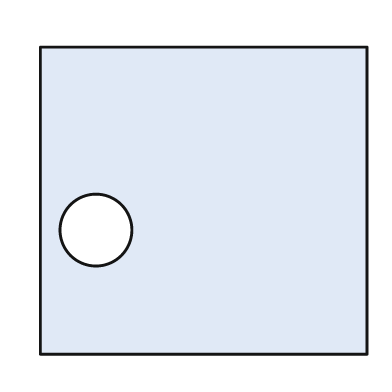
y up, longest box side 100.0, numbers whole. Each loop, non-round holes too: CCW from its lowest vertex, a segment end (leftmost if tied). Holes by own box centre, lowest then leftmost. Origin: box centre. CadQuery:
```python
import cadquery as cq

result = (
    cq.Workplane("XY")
    .moveTo(-50.0, -47.0)
    .lineTo(50.0, -47.0)
    .lineTo(50.0, 47.0)
    .lineTo(-50.0, 47.0)
    .close()
    .moveTo(-33.0, -9.0)
    .circle(11.0)
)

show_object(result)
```